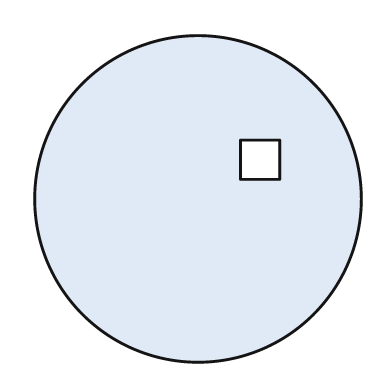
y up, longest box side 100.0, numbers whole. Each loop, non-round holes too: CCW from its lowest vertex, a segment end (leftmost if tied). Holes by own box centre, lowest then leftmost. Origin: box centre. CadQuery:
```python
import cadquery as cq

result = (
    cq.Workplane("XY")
    .moveTo(0.0, 0.0)
    .circle(50.0)
    .moveTo(13.0, 6.0)
    .lineTo(25.0, 6.0)
    .lineTo(25.0, 18.0)
    .lineTo(13.0, 18.0)
    .close()
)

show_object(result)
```